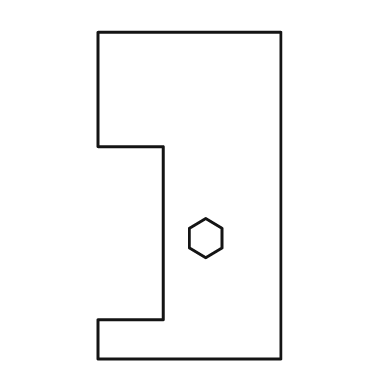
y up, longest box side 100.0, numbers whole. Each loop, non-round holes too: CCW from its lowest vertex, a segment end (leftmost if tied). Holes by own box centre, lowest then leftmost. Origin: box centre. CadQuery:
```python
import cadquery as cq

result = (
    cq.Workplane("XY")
    .moveTo(-28.0, -50.0)
    .lineTo(28.0, -50.0)
    .lineTo(28.0, 50.0)
    .lineTo(-28.0, 50.0)
    .lineTo(-28.0, 15.0)
    .lineTo(-8.0, 15.0)
    .lineTo(-8.0, -38.0)
    .lineTo(-28.0, -38.0)
    .close()
    .moveTo(5.0, -19.0)
    .lineTo(10.0, -16.0)
    .lineTo(10.0, -10.0)
    .lineTo(5.0, -7.0)
    .lineTo(0.0, -10.0)
    .lineTo(0.0, -16.0)
    .close()
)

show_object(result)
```